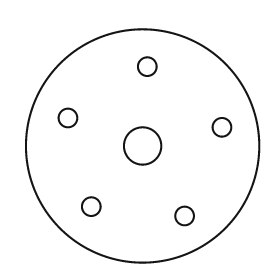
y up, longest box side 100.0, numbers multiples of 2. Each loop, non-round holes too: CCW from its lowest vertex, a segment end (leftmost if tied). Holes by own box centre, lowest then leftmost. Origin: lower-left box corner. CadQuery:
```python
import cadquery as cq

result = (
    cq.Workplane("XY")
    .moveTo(50.0, 50.0)
    .circle(50.0)
    .moveTo(68.0, 20.0)
    .circle(4.0)
    .moveTo(28.0, 24.0)
    .circle(4.0)
    .moveTo(50.0, 50.0)
    .circle(8.0)
    .moveTo(84.0, 58.0)
    .circle(4.0)
    .moveTo(18.0, 62.0)
    .circle(4.0)
    .moveTo(52.0, 84.0)
    .circle(4.0)
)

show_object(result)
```